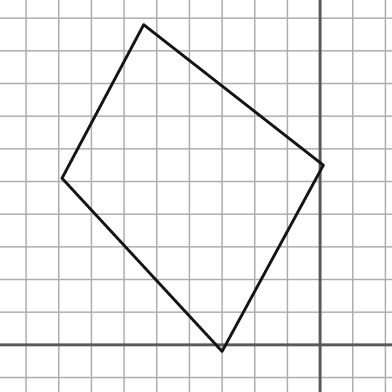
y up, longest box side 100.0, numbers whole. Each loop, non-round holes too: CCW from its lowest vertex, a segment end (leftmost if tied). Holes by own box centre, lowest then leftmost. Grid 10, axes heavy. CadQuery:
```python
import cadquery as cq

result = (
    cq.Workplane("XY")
    .moveTo(-30.0, -2.0)
    .lineTo(1.0, 55.0)
    .lineTo(-54.0, 98.0)
    .lineTo(-79.0, 51.0)
    .close()
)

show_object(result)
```